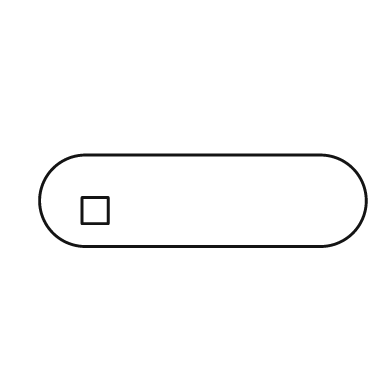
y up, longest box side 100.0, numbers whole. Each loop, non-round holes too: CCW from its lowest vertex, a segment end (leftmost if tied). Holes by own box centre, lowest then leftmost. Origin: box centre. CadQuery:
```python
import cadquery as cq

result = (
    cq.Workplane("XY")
    .moveTo(-36.0, -14.0)
    .lineTo(36.0, -14.0)
    .threePointArc((50.0, 0.0), (36.0, 14.0))
    .lineTo(-36.0, 14.0)
    .threePointArc((-50.0, 0.0), (-36.0, -14.0))
    .close()
    .moveTo(-37.0, -7.0)
    .lineTo(-29.0, -7.0)
    .lineTo(-29.0, 1.0)
    .lineTo(-37.0, 1.0)
    .close()
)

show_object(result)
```